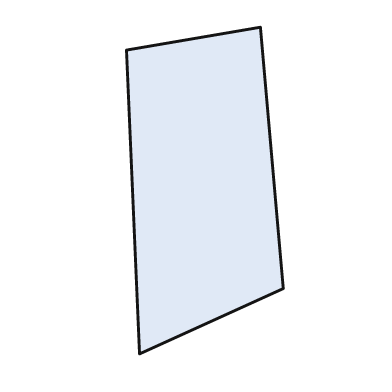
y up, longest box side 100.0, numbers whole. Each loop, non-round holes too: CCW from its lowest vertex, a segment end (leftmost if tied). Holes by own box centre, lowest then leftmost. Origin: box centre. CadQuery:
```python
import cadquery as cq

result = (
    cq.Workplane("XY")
    .moveTo(-20.0, -50.0)
    .lineTo(24.0, -30.0)
    .lineTo(17.0, 50.0)
    .lineTo(-24.0, 43.0)
    .close()
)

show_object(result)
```